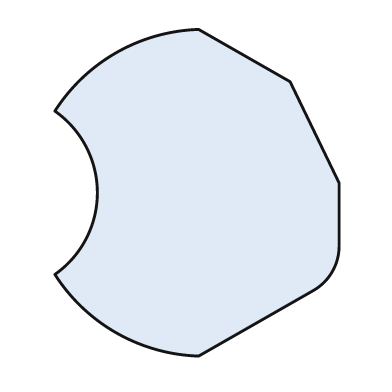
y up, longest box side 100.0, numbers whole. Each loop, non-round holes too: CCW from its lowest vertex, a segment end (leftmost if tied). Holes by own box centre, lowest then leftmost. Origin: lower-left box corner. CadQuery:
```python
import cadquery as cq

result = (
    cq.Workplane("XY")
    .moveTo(44.0, 0.0)
    .lineTo(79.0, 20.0)
    .threePointArc((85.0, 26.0), (87.0, 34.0))
    .lineTo(87.0, 53.0)
    .lineTo(72.0, 84.0)
    .lineTo(44.0, 100.0)
    .threePointArc((19.0, 93.0), (0.0, 75.0))
    .threePointArc((13.0, 50.0), (0.0, 25.0))
    .threePointArc((19.0, 7.0), (44.0, 0.0))
    .close()
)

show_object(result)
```